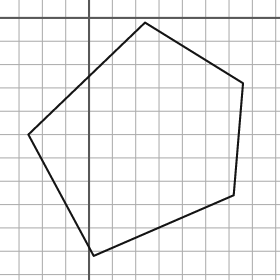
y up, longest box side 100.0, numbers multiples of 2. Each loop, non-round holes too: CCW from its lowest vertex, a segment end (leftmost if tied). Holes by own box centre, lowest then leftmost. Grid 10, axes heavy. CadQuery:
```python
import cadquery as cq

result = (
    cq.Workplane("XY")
    .moveTo(2.0, -102.0)
    .lineTo(62.0, -76.0)
    .lineTo(66.0, -28.0)
    .lineTo(24.0, -2.0)
    .lineTo(-26.0, -50.0)
    .close()
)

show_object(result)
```